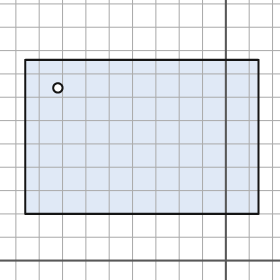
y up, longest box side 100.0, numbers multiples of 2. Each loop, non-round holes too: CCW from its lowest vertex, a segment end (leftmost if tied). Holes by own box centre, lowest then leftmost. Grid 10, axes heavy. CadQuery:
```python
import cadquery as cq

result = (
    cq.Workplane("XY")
    .moveTo(-86.0, 20.0)
    .lineTo(14.0, 20.0)
    .lineTo(14.0, 86.0)
    .lineTo(-86.0, 86.0)
    .close()
    .moveTo(-72.0, 74.0)
    .circle(2.0)
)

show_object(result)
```